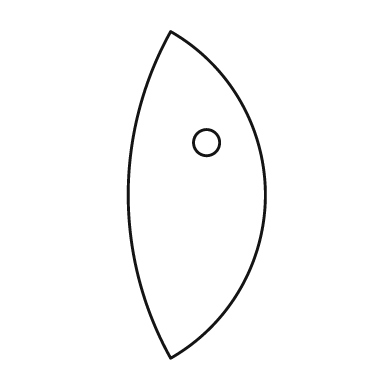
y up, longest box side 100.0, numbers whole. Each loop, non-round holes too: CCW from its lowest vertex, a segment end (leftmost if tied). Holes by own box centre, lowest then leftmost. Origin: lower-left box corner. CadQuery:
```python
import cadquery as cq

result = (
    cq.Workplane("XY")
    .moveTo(13.0, 0.0)
    .threePointArc((42.0, 50.0), (13.0, 100.0))
    .threePointArc((0.0, 50.0), (13.0, 0.0))
    .close()
    .moveTo(24.0, 66.0)
    .circle(4.0)
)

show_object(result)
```